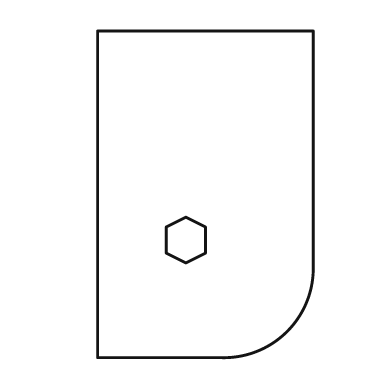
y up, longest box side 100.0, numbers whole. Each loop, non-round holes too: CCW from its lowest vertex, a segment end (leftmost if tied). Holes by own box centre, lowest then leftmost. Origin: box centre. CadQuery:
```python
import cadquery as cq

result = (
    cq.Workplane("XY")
    .moveTo(-33.0, -50.0)
    .lineTo(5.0, -50.0)
    .threePointArc((25.0, -42.0), (33.0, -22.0))
    .lineTo(33.0, 50.0)
    .lineTo(-33.0, 50.0)
    .close()
    .moveTo(-6.0, -21.0)
    .lineTo(0.0, -18.0)
    .lineTo(0.0, -10.0)
    .lineTo(-6.0, -7.0)
    .lineTo(-12.0, -10.0)
    .lineTo(-12.0, -18.0)
    .close()
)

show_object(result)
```